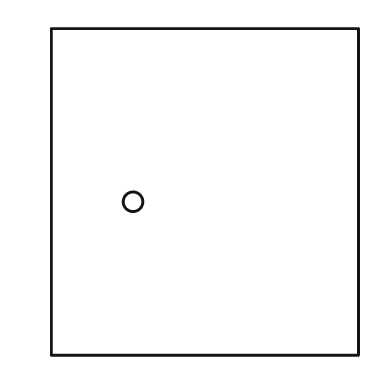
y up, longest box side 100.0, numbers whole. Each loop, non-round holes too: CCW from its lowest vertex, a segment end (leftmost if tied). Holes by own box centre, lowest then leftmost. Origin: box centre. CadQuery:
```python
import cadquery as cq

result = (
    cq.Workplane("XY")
    .moveTo(-47.0, -50.0)
    .lineTo(47.0, -50.0)
    .lineTo(47.0, 50.0)
    .lineTo(-47.0, 50.0)
    .close()
    .moveTo(-22.0, -3.0)
    .circle(3.0)
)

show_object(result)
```